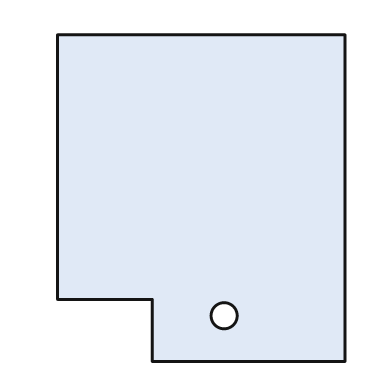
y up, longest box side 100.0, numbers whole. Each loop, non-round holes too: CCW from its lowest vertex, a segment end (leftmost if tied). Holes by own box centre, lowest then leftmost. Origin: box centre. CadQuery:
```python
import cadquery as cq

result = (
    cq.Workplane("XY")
    .moveTo(-15.0, -50.0)
    .lineTo(44.0, -50.0)
    .lineTo(44.0, 50.0)
    .lineTo(-44.0, 50.0)
    .lineTo(-44.0, -31.0)
    .lineTo(-15.0, -31.0)
    .close()
    .moveTo(7.0, -36.0)
    .circle(4.0)
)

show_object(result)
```